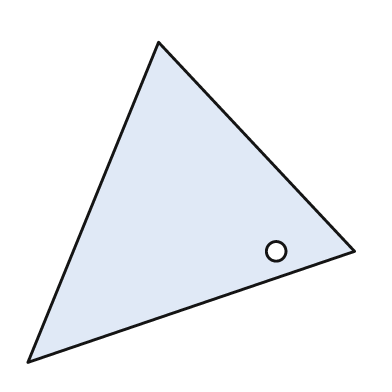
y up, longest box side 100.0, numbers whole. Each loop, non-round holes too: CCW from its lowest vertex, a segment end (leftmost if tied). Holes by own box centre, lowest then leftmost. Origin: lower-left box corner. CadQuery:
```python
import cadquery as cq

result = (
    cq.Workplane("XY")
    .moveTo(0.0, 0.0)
    .lineTo(100.0, 34.0)
    .lineTo(40.0, 98.0)
    .close()
    .moveTo(76.0, 34.0)
    .circle(3.0)
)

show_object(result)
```